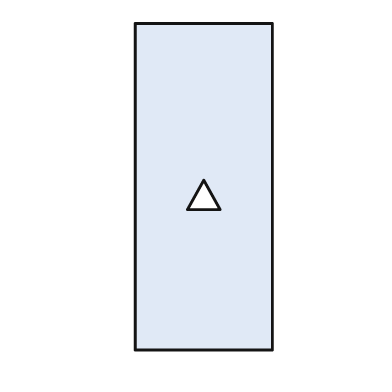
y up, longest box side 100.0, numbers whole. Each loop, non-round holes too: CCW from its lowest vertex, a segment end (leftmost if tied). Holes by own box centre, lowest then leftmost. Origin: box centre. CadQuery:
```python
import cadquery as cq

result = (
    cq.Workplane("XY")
    .moveTo(-21.0, -50.0)
    .lineTo(21.0, -50.0)
    .lineTo(21.0, 50.0)
    .lineTo(-21.0, 50.0)
    .close()
    .moveTo(-5.0, -7.0)
    .lineTo(5.0, -7.0)
    .lineTo(0.0, 2.0)
    .close()
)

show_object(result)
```